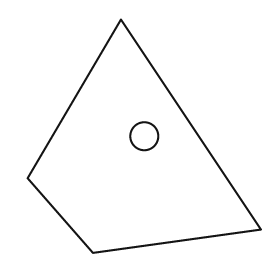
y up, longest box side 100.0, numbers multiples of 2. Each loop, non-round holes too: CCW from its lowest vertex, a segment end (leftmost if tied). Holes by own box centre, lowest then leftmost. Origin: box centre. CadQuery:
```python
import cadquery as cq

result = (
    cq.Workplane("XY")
    .moveTo(-22.0, -50.0)
    .lineTo(50.0, -40.0)
    .lineTo(-10.0, 50.0)
    .lineTo(-50.0, -18.0)
    .close()
    .moveTo(0.0, 0.0)
    .circle(6.0)
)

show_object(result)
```